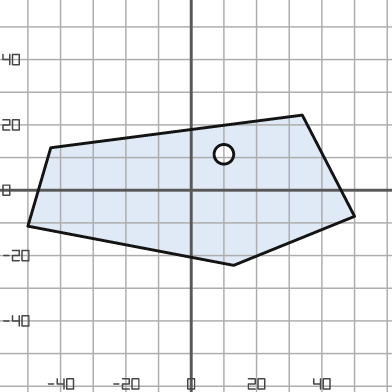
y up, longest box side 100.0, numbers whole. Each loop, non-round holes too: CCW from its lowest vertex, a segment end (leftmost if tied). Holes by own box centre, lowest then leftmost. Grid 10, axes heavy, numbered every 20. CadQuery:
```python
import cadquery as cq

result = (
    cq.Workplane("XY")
    .moveTo(13.0, -23.0)
    .lineTo(50.0, -8.0)
    .lineTo(34.0, 23.0)
    .lineTo(-43.0, 13.0)
    .lineTo(-50.0, -11.0)
    .close()
    .moveTo(10.0, 11.0)
    .circle(3.0)
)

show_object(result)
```